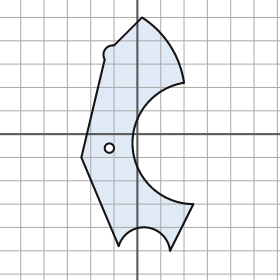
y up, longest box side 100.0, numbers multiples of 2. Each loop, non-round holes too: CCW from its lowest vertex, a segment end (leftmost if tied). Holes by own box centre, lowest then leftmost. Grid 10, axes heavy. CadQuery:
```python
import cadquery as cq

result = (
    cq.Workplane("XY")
    .moveTo(14.0, -50.0)
    .lineTo(24.0, -30.0)
    .threePointArc((-2.0, -6.0), (20.0, 22.0))
    .threePointArc((14.0, 38.0), (2.0, 50.0))
    .lineTo(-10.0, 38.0)
    .threePointArc((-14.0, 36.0), (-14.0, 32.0))
    .lineTo(-24.0, -10.0)
    .lineTo(-8.0, -48.0)
    .threePointArc((4.0, -40.0), (14.0, -50.0))
    .close()
    .moveTo(-12.0, -6.0)
    .circle(2.0)
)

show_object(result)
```